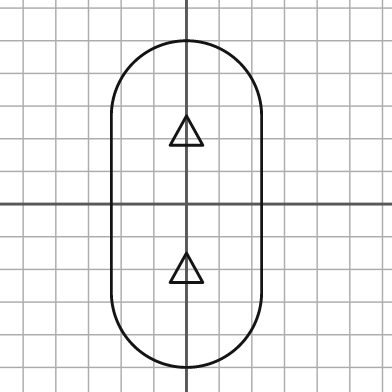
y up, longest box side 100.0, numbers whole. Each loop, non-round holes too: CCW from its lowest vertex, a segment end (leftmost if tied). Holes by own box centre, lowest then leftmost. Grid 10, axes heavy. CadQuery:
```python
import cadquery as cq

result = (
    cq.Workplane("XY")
    .moveTo(-23.0, -27.0)
    .threePointArc((0.0, -50.0), (23.0, -27.0))
    .lineTo(23.0, 27.0)
    .threePointArc((0.0, 50.0), (-23.0, 27.0))
    .close()
    .moveTo(-5.0, -24.0)
    .lineTo(5.0, -24.0)
    .lineTo(0.0, -15.0)
    .close()
    .moveTo(-5.0, 18.0)
    .lineTo(5.0, 18.0)
    .lineTo(0.0, 27.0)
    .close()
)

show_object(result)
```